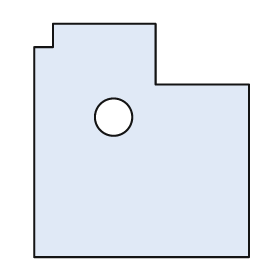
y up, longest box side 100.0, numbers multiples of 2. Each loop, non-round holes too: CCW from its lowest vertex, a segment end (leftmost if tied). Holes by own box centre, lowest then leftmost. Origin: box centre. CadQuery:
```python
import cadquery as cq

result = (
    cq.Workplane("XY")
    .moveTo(-46.0, -50.0)
    .lineTo(46.0, -50.0)
    .lineTo(46.0, 24.0)
    .lineTo(6.0, 24.0)
    .lineTo(6.0, 50.0)
    .lineTo(-38.0, 50.0)
    .lineTo(-38.0, 40.0)
    .lineTo(-46.0, 40.0)
    .close()
    .moveTo(-12.0, 10.0)
    .circle(8.0)
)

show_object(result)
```